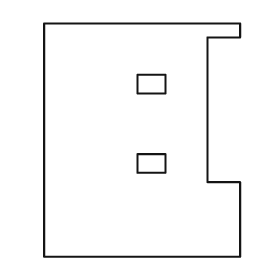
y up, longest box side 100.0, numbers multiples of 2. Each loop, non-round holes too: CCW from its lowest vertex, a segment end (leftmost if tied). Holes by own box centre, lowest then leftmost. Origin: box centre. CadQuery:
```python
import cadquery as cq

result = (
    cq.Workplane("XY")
    .moveTo(-42.0, -50.0)
    .lineTo(42.0, -50.0)
    .lineTo(42.0, -18.0)
    .lineTo(28.0, -18.0)
    .lineTo(28.0, 44.0)
    .lineTo(42.0, 44.0)
    .lineTo(42.0, 50.0)
    .lineTo(-42.0, 50.0)
    .close()
    .moveTo(-2.0, -14.0)
    .lineTo(10.0, -14.0)
    .lineTo(10.0, -6.0)
    .lineTo(-2.0, -6.0)
    .close()
    .moveTo(-2.0, 20.0)
    .lineTo(10.0, 20.0)
    .lineTo(10.0, 28.0)
    .lineTo(-2.0, 28.0)
    .close()
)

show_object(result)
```